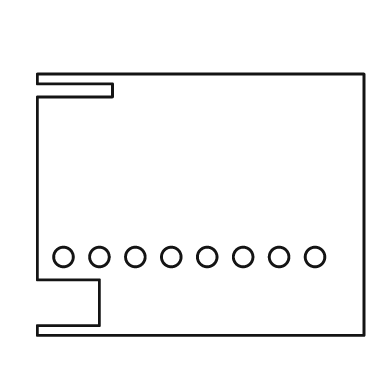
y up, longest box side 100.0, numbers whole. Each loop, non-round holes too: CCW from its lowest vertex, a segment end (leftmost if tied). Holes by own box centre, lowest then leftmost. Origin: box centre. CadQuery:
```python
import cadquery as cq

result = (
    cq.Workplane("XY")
    .moveTo(-50.0, -40.0)
    .lineTo(50.0, -40.0)
    .lineTo(50.0, 40.0)
    .lineTo(-50.0, 40.0)
    .lineTo(-50.0, 37.0)
    .lineTo(-27.0, 37.0)
    .lineTo(-27.0, 33.0)
    .lineTo(-50.0, 33.0)
    .lineTo(-50.0, -23.0)
    .lineTo(-31.0, -23.0)
    .lineTo(-31.0, -37.0)
    .lineTo(-50.0, -37.0)
    .close()
    .moveTo(-42.0, -16.0)
    .circle(3.0)
    .moveTo(-31.0, -16.0)
    .circle(3.0)
    .moveTo(-20.0, -16.0)
    .circle(3.0)
    .moveTo(-9.0, -16.0)
    .circle(3.0)
    .moveTo(2.0, -16.0)
    .circle(3.0)
    .moveTo(13.0, -16.0)
    .circle(3.0)
    .moveTo(24.0, -16.0)
    .circle(3.0)
    .moveTo(35.0, -16.0)
    .circle(3.0)
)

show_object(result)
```